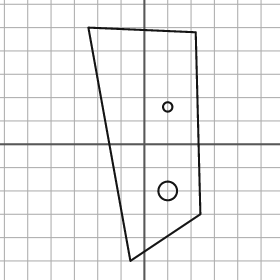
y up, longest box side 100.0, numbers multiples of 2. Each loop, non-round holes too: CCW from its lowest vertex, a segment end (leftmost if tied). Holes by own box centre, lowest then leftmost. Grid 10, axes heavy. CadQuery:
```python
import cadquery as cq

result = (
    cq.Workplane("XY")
    .moveTo(-6.0, -50.0)
    .lineTo(24.0, -30.0)
    .lineTo(22.0, 48.0)
    .lineTo(-24.0, 50.0)
    .close()
    .moveTo(10.0, -20.0)
    .circle(4.0)
    .moveTo(10.0, 16.0)
    .circle(2.0)
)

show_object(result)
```